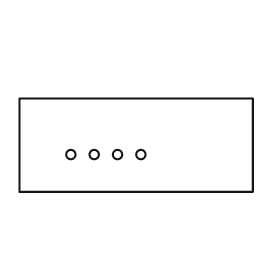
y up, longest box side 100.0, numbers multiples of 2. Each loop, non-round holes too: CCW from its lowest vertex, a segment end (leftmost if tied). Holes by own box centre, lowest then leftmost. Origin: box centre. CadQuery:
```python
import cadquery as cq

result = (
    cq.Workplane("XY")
    .moveTo(-50.0, -20.0)
    .lineTo(50.0, -20.0)
    .lineTo(50.0, 20.0)
    .lineTo(-50.0, 20.0)
    .close()
    .moveTo(-28.0, -4.0)
    .circle(2.0)
    .moveTo(-18.0, -4.0)
    .circle(2.0)
    .moveTo(-8.0, -4.0)
    .circle(2.0)
    .moveTo(2.0, -4.0)
    .circle(2.0)
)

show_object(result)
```